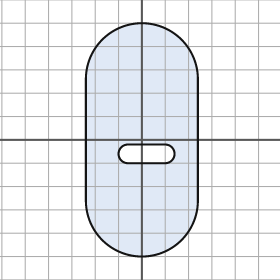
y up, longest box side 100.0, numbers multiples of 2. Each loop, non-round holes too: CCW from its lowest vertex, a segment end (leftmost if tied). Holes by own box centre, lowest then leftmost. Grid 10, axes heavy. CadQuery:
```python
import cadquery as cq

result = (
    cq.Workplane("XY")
    .moveTo(-24.0, -26.0)
    .threePointArc((0.0, -50.0), (24.0, -26.0))
    .lineTo(24.0, 26.0)
    .threePointArc((0.0, 50.0), (-24.0, 26.0))
    .close()
    .moveTo(-6.0, -10.0)
    .lineTo(10.0, -10.0)
    .threePointArc((14.0, -6.0), (10.0, -2.0))
    .lineTo(-6.0, -2.0)
    .threePointArc((-10.0, -6.0), (-6.0, -10.0))
    .close()
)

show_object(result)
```